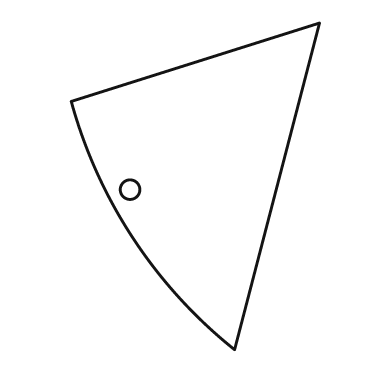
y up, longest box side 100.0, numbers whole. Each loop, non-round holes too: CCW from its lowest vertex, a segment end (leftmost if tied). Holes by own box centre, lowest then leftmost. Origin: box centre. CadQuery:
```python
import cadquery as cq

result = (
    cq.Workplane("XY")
    .moveTo(12.0, -50.0)
    .lineTo(38.0, 50.0)
    .lineTo(-38.0, 26.0)
    .threePointArc((-19.0, -16.0), (12.0, -50.0))
    .close()
    .moveTo(-20.0, -1.0)
    .circle(3.0)
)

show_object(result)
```